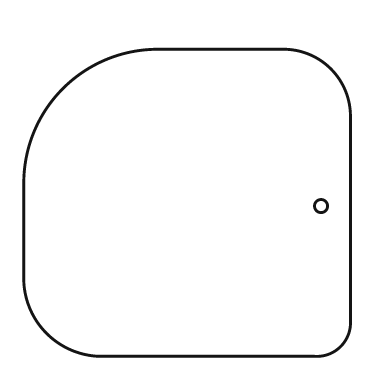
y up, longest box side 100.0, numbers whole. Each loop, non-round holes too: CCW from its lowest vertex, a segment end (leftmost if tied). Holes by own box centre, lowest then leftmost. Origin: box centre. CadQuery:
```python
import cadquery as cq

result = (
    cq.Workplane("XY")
    .moveTo(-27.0, -47.0)
    .lineTo(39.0, -47.0)
    .threePointArc((47.0, -44.0), (50.0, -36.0))
    .lineTo(50.0, 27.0)
    .threePointArc((44.0, 41.0), (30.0, 47.0))
    .lineTo(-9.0, 47.0)
    .threePointArc((-38.0, 35.0), (-50.0, 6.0))
    .lineTo(-50.0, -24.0)
    .threePointArc((-43.0, -40.0), (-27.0, -47.0))
    .close()
    .moveTo(41.0, -1.0)
    .circle(2.0)
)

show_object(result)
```